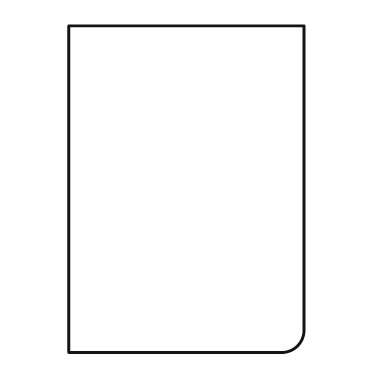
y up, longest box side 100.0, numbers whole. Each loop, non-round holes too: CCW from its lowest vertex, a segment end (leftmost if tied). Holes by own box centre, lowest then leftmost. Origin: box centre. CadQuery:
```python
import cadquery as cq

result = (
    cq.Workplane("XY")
    .moveTo(-36.0, -50.0)
    .lineTo(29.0, -50.0)
    .threePointArc((34.0, -48.0), (36.0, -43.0))
    .lineTo(36.0, 50.0)
    .lineTo(-36.0, 50.0)
    .close()
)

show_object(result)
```